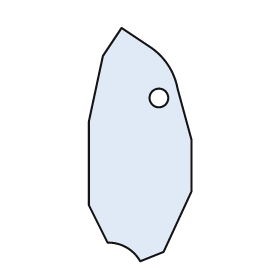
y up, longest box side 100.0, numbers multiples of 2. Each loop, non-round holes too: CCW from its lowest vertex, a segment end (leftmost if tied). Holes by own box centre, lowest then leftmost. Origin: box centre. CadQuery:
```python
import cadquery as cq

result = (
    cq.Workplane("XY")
    .moveTo(0.0, -50.0)
    .lineTo(10.0, -46.0)
    .lineTo(22.0, -20.0)
    .lineTo(22.0, 2.0)
    .lineTo(16.0, 24.0)
    .threePointArc((12.0, 34.0), (4.0, 42.0))
    .lineTo(-8.0, 50.0)
    .lineTo(-16.0, 38.0)
    .lineTo(-22.0, 10.0)
    .lineTo(-22.0, -26.0)
    .lineTo(-14.0, -42.0)
    .threePointArc((-6.0, -44.0), (0.0, -50.0))
    .close()
    .moveTo(8.0, 20.0)
    .circle(4.0)
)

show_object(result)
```